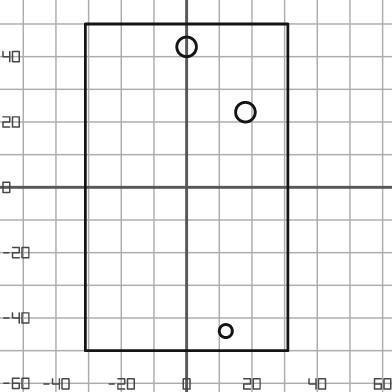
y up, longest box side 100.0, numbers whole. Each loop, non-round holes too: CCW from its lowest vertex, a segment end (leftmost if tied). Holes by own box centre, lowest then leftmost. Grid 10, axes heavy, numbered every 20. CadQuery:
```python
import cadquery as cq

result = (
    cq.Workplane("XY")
    .moveTo(-31.0, -50.0)
    .lineTo(31.0, -50.0)
    .lineTo(31.0, 50.0)
    .lineTo(-31.0, 50.0)
    .close()
    .moveTo(12.0, -44.0)
    .circle(2.0)
    .moveTo(18.0, 23.0)
    .circle(3.0)
    .moveTo(0.0, 43.0)
    .circle(3.0)
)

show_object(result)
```